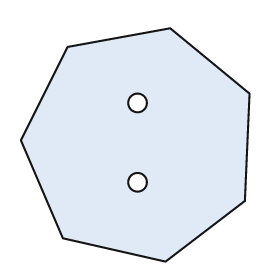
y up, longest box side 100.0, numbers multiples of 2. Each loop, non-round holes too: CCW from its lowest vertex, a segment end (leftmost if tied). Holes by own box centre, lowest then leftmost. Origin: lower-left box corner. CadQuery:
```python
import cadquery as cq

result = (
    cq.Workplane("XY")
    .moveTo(62.0, 0.0)
    .lineTo(96.0, 26.0)
    .lineTo(98.0, 72.0)
    .lineTo(64.0, 100.0)
    .lineTo(20.0, 92.0)
    .lineTo(0.0, 52.0)
    .lineTo(18.0, 10.0)
    .close()
    .moveTo(50.0, 34.0)
    .circle(4.0)
    .moveTo(50.0, 68.0)
    .circle(4.0)
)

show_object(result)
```